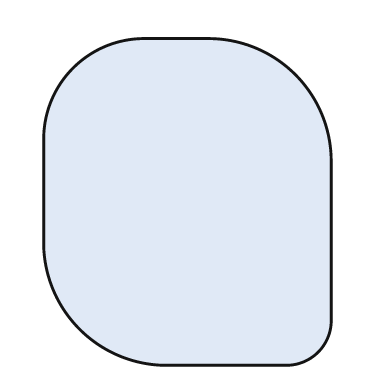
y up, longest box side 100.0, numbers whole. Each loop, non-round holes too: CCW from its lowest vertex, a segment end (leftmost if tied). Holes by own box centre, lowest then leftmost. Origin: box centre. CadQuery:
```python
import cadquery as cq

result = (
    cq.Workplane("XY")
    .moveTo(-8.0, -50.0)
    .lineTo(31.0, -50.0)
    .threePointArc((40.0, -46.0), (44.0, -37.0))
    .lineTo(44.0, 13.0)
    .threePointArc((33.0, 39.0), (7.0, 50.0))
    .lineTo(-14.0, 50.0)
    .threePointArc((-35.0, 41.0), (-44.0, 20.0))
    .lineTo(-44.0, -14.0)
    .threePointArc((-33.0, -39.0), (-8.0, -50.0))
    .close()
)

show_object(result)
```